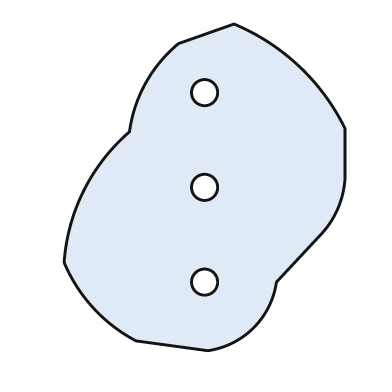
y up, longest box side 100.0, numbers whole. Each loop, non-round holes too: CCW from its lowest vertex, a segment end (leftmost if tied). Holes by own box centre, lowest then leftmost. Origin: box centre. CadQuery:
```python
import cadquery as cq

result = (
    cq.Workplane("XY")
    .moveTo(1.0, -50.0)
    .threePointArc((15.0, -43.0), (22.0, -29.0))
    .lineTo(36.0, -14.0)
    .threePointArc((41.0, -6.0), (43.0, 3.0))
    .lineTo(43.0, 18.0)
    .threePointArc((29.0, 37.0), (9.0, 50.0))
    .lineTo(-8.0, 44.0)
    .threePointArc((-18.0, 32.0), (-23.0, 17.0))
    .threePointArc((-37.0, -1.0), (-43.0, -23.0))
    .threePointArc((-34.0, -37.0), (-21.0, -47.0))
    .close()
    .moveTo(0.0, -29.0)
    .circle(4.0)
    .moveTo(0.0, 0.0)
    .circle(4.0)
    .moveTo(0.0, 29.0)
    .circle(4.0)
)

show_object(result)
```